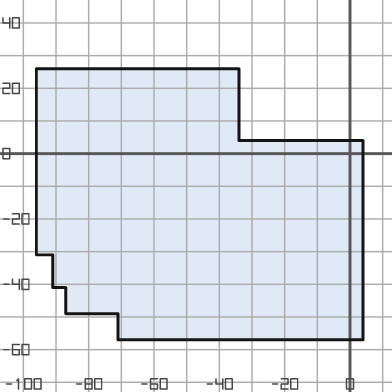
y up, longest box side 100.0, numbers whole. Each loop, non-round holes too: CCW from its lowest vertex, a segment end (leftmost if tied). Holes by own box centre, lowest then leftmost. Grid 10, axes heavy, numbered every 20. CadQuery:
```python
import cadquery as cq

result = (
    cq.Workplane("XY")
    .moveTo(-71.0, -57.0)
    .lineTo(4.0, -57.0)
    .lineTo(4.0, 4.0)
    .lineTo(-34.0, 4.0)
    .lineTo(-34.0, 26.0)
    .lineTo(-96.0, 26.0)
    .lineTo(-96.0, -31.0)
    .lineTo(-91.0, -31.0)
    .lineTo(-91.0, -41.0)
    .lineTo(-87.0, -41.0)
    .lineTo(-87.0, -49.0)
    .lineTo(-71.0, -49.0)
    .close()
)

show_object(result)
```